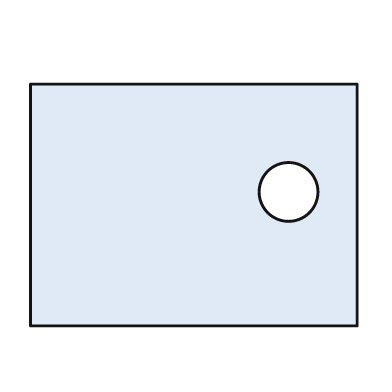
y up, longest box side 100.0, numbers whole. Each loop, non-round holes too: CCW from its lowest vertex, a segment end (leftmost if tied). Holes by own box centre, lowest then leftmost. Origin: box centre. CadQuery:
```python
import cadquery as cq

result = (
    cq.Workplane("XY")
    .moveTo(-50.0, -37.0)
    .lineTo(50.0, -37.0)
    .lineTo(50.0, 37.0)
    .lineTo(-50.0, 37.0)
    .close()
    .moveTo(29.0, 4.0)
    .circle(9.0)
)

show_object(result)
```